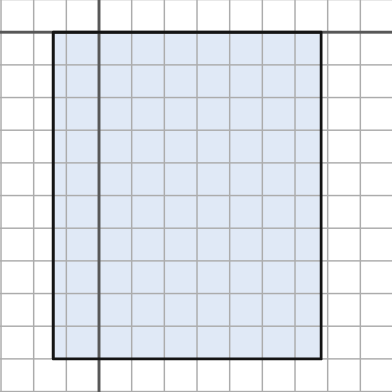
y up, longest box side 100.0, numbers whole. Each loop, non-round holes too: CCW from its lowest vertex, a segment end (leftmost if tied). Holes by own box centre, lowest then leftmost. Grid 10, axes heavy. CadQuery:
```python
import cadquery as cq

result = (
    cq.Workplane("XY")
    .moveTo(-14.0, -100.0)
    .lineTo(68.0, -100.0)
    .lineTo(68.0, 0.0)
    .lineTo(-14.0, 0.0)
    .close()
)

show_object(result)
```